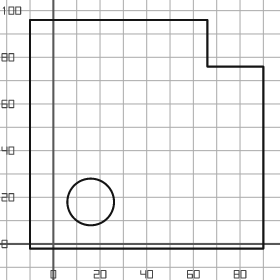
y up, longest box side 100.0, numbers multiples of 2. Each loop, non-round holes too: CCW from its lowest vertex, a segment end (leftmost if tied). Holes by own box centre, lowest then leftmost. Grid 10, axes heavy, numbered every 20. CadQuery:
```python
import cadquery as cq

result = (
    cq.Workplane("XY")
    .moveTo(-10.0, -2.0)
    .lineTo(90.0, -2.0)
    .lineTo(90.0, 76.0)
    .lineTo(66.0, 76.0)
    .lineTo(66.0, 96.0)
    .lineTo(-10.0, 96.0)
    .close()
    .moveTo(16.0, 18.0)
    .circle(10.0)
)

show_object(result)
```